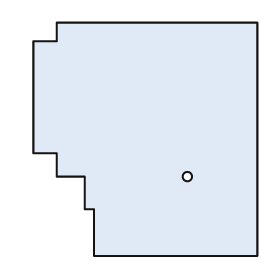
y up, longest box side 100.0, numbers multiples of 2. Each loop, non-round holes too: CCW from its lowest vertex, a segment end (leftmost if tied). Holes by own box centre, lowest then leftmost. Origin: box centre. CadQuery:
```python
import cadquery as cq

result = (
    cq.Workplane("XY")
    .moveTo(-22.0, -50.0)
    .lineTo(48.0, -50.0)
    .lineTo(48.0, 50.0)
    .lineTo(-38.0, 50.0)
    .lineTo(-38.0, 42.0)
    .lineTo(-48.0, 42.0)
    .lineTo(-48.0, -6.0)
    .lineTo(-38.0, -6.0)
    .lineTo(-38.0, -16.0)
    .lineTo(-26.0, -16.0)
    .lineTo(-26.0, -30.0)
    .lineTo(-22.0, -30.0)
    .close()
    .moveTo(18.0, -16.0)
    .circle(2.0)
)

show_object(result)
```